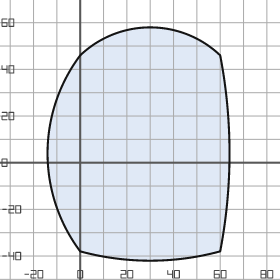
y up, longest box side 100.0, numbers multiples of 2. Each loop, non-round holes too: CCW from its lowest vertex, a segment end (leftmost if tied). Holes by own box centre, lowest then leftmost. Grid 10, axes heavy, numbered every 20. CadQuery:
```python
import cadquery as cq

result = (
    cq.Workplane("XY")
    .moveTo(0.0, -38.0)
    .threePointArc((30.0, -42.0), (60.0, -38.0))
    .threePointArc((64.0, 4.0), (60.0, 46.0))
    .threePointArc((30.0, 58.0), (0.0, 46.0))
    .threePointArc((-14.0, 4.0), (0.0, -38.0))
    .close()
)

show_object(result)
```